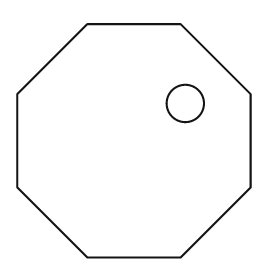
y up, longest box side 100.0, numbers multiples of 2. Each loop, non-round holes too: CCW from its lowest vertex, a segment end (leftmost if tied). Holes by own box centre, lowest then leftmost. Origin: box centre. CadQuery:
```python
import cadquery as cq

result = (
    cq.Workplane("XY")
    .moveTo(-20.0, -50.0)
    .lineTo(20.0, -50.0)
    .lineTo(50.0, -20.0)
    .lineTo(50.0, 20.0)
    .lineTo(20.0, 50.0)
    .lineTo(-20.0, 50.0)
    .lineTo(-50.0, 20.0)
    .lineTo(-50.0, -20.0)
    .close()
    .moveTo(22.0, 16.0)
    .circle(8.0)
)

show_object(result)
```